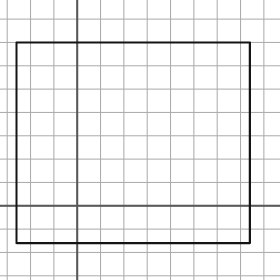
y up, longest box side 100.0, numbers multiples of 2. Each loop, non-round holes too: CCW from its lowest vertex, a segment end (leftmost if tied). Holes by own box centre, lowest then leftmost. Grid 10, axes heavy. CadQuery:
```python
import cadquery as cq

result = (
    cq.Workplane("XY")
    .moveTo(-26.0, -16.0)
    .lineTo(74.0, -16.0)
    .lineTo(74.0, 70.0)
    .lineTo(-26.0, 70.0)
    .close()
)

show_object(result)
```